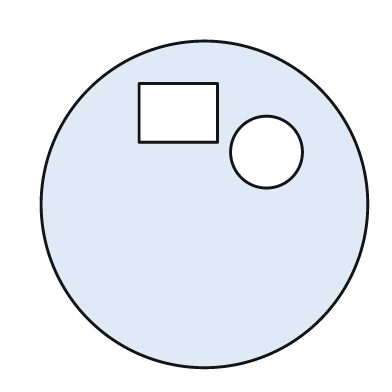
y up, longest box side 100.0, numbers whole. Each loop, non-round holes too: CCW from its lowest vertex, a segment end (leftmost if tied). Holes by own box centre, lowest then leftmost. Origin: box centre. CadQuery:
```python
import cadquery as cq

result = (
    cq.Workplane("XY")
    .moveTo(0.0, 0.0)
    .circle(50.0)
    .moveTo(19.0, 16.0)
    .circle(11.0)
    .moveTo(-20.0, 19.0)
    .lineTo(4.0, 19.0)
    .lineTo(4.0, 37.0)
    .lineTo(-20.0, 37.0)
    .close()
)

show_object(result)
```